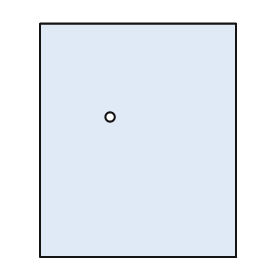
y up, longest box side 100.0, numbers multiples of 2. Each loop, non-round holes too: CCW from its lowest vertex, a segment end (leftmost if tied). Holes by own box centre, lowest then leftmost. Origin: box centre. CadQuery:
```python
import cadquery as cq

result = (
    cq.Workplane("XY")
    .moveTo(-42.0, -50.0)
    .lineTo(42.0, -50.0)
    .lineTo(42.0, 50.0)
    .lineTo(-42.0, 50.0)
    .close()
    .moveTo(-12.0, 10.0)
    .circle(2.0)
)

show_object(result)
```